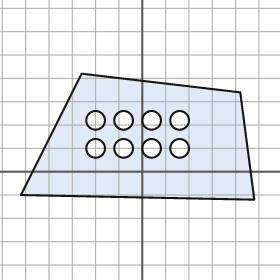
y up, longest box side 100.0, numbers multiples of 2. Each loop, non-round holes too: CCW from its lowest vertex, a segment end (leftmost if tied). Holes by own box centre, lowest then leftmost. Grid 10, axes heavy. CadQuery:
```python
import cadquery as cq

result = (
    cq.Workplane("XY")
    .moveTo(48.0, -12.0)
    .lineTo(42.0, 34.0)
    .lineTo(-26.0, 42.0)
    .lineTo(-52.0, -10.0)
    .close()
    .moveTo(-20.0, 10.0)
    .circle(4.0)
    .moveTo(-8.0, 10.0)
    .circle(4.0)
    .moveTo(4.0, 10.0)
    .circle(4.0)
    .moveTo(16.0, 10.0)
    .circle(4.0)
    .moveTo(-20.0, 22.0)
    .circle(4.0)
    .moveTo(-8.0, 22.0)
    .circle(4.0)
    .moveTo(4.0, 22.0)
    .circle(4.0)
    .moveTo(16.0, 22.0)
    .circle(4.0)
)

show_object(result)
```